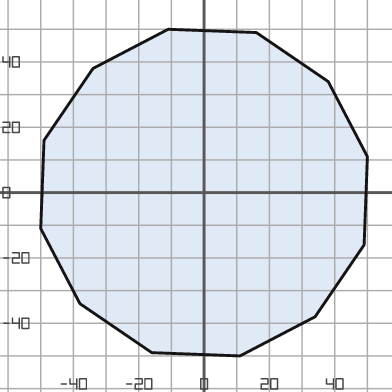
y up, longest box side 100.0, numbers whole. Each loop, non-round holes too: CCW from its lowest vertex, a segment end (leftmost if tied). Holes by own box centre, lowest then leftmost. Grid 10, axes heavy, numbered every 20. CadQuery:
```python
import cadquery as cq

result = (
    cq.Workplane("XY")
    .moveTo(11.0, -50.0)
    .lineTo(34.0, -38.0)
    .lineTo(49.0, -16.0)
    .lineTo(50.0, 11.0)
    .lineTo(38.0, 34.0)
    .lineTo(16.0, 49.0)
    .lineTo(-11.0, 50.0)
    .lineTo(-34.0, 38.0)
    .lineTo(-49.0, 16.0)
    .lineTo(-50.0, -11.0)
    .lineTo(-38.0, -34.0)
    .lineTo(-16.0, -49.0)
    .close()
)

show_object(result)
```